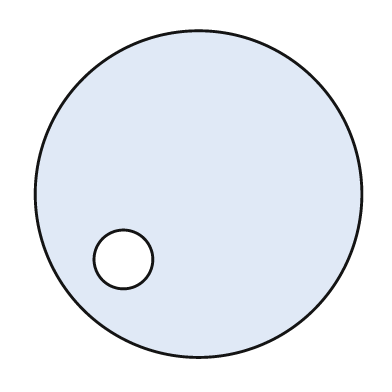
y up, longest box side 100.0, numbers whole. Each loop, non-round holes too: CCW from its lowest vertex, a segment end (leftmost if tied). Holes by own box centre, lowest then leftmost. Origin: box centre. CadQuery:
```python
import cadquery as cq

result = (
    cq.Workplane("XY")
    .moveTo(0.0, 0.0)
    .circle(50.0)
    .moveTo(-23.0, -20.0)
    .circle(9.0)
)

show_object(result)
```